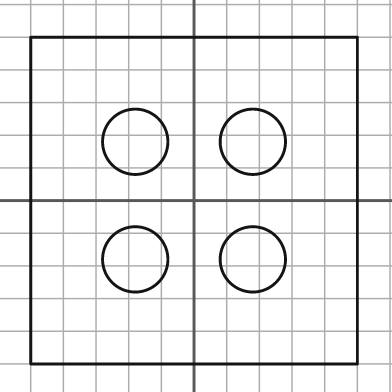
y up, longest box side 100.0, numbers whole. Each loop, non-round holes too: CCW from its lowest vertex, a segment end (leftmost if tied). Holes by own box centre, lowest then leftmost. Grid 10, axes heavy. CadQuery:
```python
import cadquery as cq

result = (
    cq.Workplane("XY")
    .moveTo(-50.0, -50.0)
    .lineTo(50.0, -50.0)
    .lineTo(50.0, 50.0)
    .lineTo(-50.0, 50.0)
    .close()
    .moveTo(-18.0, -18.0)
    .circle(10.0)
    .moveTo(18.0, -18.0)
    .circle(10.0)
    .moveTo(-18.0, 18.0)
    .circle(10.0)
    .moveTo(18.0, 18.0)
    .circle(10.0)
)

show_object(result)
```